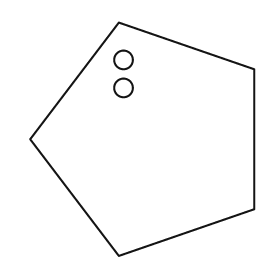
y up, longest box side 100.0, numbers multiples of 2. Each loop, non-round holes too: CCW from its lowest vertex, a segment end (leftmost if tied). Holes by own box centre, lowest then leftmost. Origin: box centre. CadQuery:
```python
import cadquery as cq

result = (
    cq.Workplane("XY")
    .moveTo(-10.0, -50.0)
    .lineTo(48.0, -30.0)
    .lineTo(48.0, 30.0)
    .lineTo(-10.0, 50.0)
    .lineTo(-48.0, 0.0)
    .close()
    .moveTo(-8.0, 22.0)
    .circle(4.0)
    .moveTo(-8.0, 34.0)
    .circle(4.0)
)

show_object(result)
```